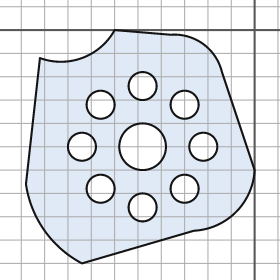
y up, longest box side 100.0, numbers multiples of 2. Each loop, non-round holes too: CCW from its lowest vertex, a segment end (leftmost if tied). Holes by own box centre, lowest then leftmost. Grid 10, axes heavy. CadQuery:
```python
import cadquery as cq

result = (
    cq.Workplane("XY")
    .moveTo(-74.0, -100.0)
    .lineTo(-26.0, -86.0)
    .threePointArc((-8.0, -78.0), (0.0, -60.0))
    .lineTo(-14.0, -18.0)
    .threePointArc((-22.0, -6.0), (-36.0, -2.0))
    .lineTo(-60.0, 0.0)
    .threePointArc((-74.0, -12.0), (-92.0, -12.0))
    .lineTo(-98.0, -66.0)
    .threePointArc((-90.0, -86.0), (-74.0, -100.0))
    .close()
    .moveTo(-48.0, -76.0)
    .circle(6.0)
    .moveTo(-66.0, -68.0)
    .circle(6.0)
    .moveTo(-30.0, -68.0)
    .circle(6.0)
    .moveTo(-74.0, -50.0)
    .circle(6.0)
    .moveTo(-48.0, -50.0)
    .circle(10.0)
    .moveTo(-22.0, -50.0)
    .circle(6.0)
    .moveTo(-66.0, -32.0)
    .circle(6.0)
    .moveTo(-30.0, -32.0)
    .circle(6.0)
    .moveTo(-48.0, -24.0)
    .circle(6.0)
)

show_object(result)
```